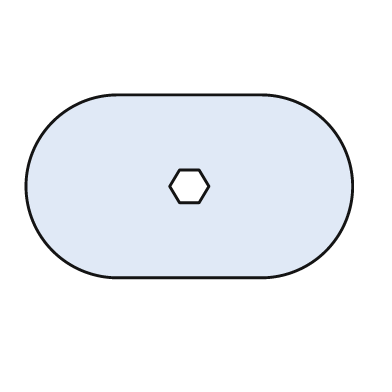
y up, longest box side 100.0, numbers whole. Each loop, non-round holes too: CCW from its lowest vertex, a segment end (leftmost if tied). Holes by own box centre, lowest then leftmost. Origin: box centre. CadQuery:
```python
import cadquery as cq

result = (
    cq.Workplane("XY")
    .moveTo(-22.0, -28.0)
    .lineTo(22.0, -28.0)
    .threePointArc((50.0, 0.0), (22.0, 28.0))
    .lineTo(-22.0, 28.0)
    .threePointArc((-50.0, 0.0), (-22.0, -28.0))
    .close()
    .moveTo(-3.0, -5.0)
    .lineTo(3.0, -5.0)
    .lineTo(6.0, 0.0)
    .lineTo(3.0, 5.0)
    .lineTo(-3.0, 5.0)
    .lineTo(-6.0, 0.0)
    .close()
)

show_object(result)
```